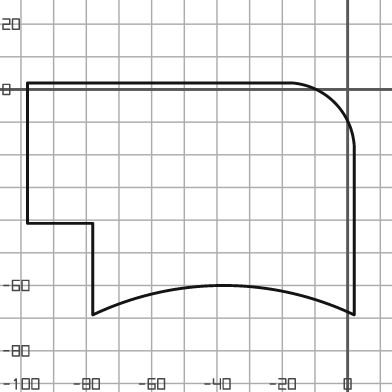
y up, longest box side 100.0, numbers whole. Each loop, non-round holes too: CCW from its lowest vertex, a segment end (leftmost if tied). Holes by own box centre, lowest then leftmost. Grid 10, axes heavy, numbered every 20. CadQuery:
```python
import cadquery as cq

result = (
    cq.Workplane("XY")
    .moveTo(-78.0, -69.0)
    .threePointArc((-38.0, -60.0), (2.0, -69.0))
    .lineTo(2.0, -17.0)
    .threePointArc((-4.0, -4.0), (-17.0, 2.0))
    .lineTo(-98.0, 2.0)
    .lineTo(-98.0, -41.0)
    .lineTo(-78.0, -41.0)
    .close()
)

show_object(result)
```